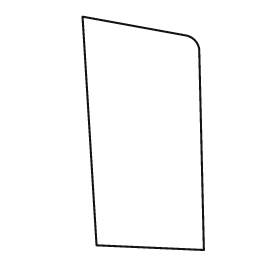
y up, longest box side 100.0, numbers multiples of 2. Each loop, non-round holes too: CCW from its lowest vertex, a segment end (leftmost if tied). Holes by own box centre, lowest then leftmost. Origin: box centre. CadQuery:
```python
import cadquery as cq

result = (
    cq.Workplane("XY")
    .moveTo(26.0, -50.0)
    .lineTo(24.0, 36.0)
    .threePointArc((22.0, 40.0), (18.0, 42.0))
    .lineTo(-26.0, 50.0)
    .lineTo(-20.0, -48.0)
    .close()
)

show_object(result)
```